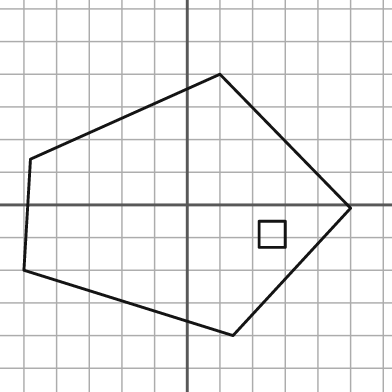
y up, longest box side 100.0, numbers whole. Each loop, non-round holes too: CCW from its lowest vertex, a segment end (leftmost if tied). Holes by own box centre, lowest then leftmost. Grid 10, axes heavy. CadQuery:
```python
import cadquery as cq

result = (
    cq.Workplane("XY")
    .moveTo(14.0, -40.0)
    .lineTo(50.0, -1.0)
    .lineTo(10.0, 40.0)
    .lineTo(-48.0, 14.0)
    .lineTo(-50.0, -20.0)
    .close()
    .moveTo(22.0, -13.0)
    .lineTo(30.0, -13.0)
    .lineTo(30.0, -5.0)
    .lineTo(22.0, -5.0)
    .close()
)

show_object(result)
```